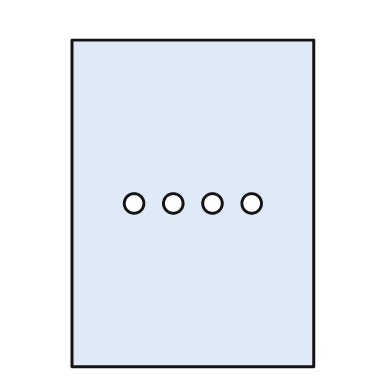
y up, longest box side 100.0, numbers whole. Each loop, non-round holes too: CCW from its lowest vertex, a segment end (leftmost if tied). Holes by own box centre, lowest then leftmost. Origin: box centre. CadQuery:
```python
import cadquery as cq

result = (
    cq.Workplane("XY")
    .moveTo(-37.0, -50.0)
    .lineTo(37.0, -50.0)
    .lineTo(37.0, 50.0)
    .lineTo(-37.0, 50.0)
    .close()
    .moveTo(-18.0, 0.0)
    .circle(3.0)
    .moveTo(-6.0, 0.0)
    .circle(3.0)
    .moveTo(6.0, 0.0)
    .circle(3.0)
    .moveTo(18.0, 0.0)
    .circle(3.0)
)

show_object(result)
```